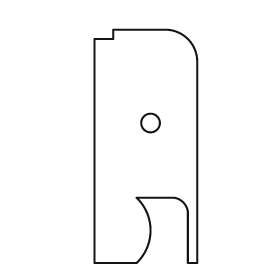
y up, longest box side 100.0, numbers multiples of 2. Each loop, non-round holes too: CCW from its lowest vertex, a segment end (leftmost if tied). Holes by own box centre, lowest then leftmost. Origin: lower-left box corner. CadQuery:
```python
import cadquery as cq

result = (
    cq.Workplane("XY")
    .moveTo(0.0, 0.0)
    .lineTo(18.0, 0.0)
    .threePointArc((24.0, 14.0), (18.0, 28.0))
    .lineTo(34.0, 28.0)
    .threePointArc((38.0, 26.0), (40.0, 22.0))
    .lineTo(40.0, 0.0)
    .lineTo(44.0, 0.0)
    .lineTo(44.0, 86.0)
    .threePointArc((40.0, 96.0), (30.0, 100.0))
    .lineTo(8.0, 100.0)
    .lineTo(8.0, 96.0)
    .lineTo(0.0, 96.0)
    .close()
    .moveTo(24.0, 60.0)
    .circle(4.0)
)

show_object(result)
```